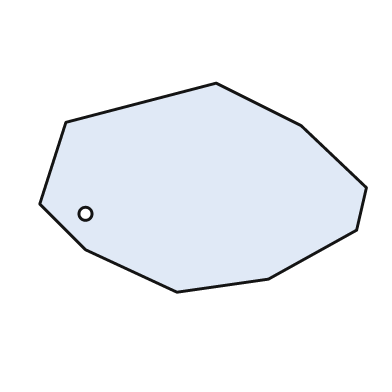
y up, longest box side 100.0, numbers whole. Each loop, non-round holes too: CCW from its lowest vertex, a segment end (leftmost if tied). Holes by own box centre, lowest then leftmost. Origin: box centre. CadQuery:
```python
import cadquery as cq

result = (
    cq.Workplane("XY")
    .moveTo(-8.0, -32.0)
    .lineTo(20.0, -28.0)
    .lineTo(47.0, -13.0)
    .lineTo(50.0, 0.0)
    .lineTo(30.0, 19.0)
    .lineTo(4.0, 32.0)
    .lineTo(-42.0, 20.0)
    .lineTo(-50.0, -5.0)
    .lineTo(-36.0, -19.0)
    .close()
    .moveTo(-36.0, -8.0)
    .circle(2.0)
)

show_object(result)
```